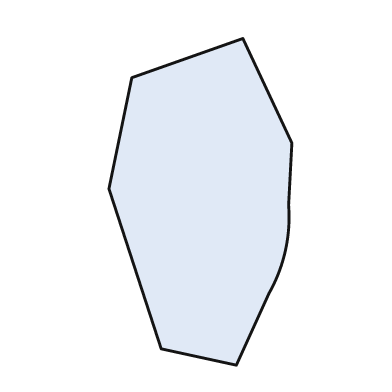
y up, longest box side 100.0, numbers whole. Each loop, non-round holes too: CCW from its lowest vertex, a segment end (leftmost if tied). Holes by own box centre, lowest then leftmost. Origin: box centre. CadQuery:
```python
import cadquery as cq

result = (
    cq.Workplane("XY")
    .moveTo(11.0, -50.0)
    .lineTo(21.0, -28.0)
    .threePointArc((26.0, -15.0), (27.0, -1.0))
    .lineTo(28.0, 18.0)
    .lineTo(13.0, 50.0)
    .lineTo(-21.0, 38.0)
    .lineTo(-28.0, 4.0)
    .lineTo(-12.0, -45.0)
    .close()
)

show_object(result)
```